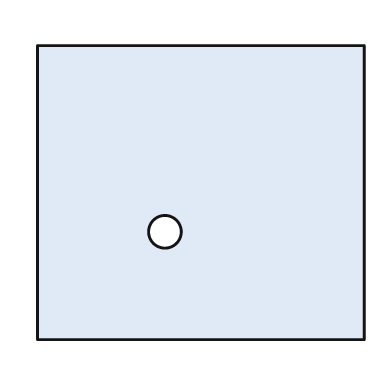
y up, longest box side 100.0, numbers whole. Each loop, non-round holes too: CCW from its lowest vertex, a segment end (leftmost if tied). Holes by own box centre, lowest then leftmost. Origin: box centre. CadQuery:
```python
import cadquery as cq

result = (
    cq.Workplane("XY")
    .moveTo(-50.0, -45.0)
    .lineTo(50.0, -45.0)
    .lineTo(50.0, 45.0)
    .lineTo(-50.0, 45.0)
    .close()
    .moveTo(-11.0, -12.0)
    .circle(5.0)
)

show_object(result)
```